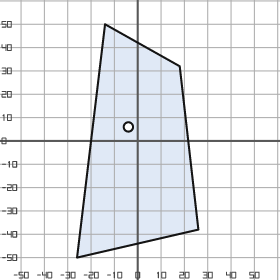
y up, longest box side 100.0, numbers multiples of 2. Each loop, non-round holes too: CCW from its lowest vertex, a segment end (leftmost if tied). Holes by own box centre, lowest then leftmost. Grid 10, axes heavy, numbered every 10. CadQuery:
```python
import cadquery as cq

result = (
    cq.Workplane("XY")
    .moveTo(-26.0, -50.0)
    .lineTo(26.0, -38.0)
    .lineTo(18.0, 32.0)
    .lineTo(-14.0, 50.0)
    .close()
    .moveTo(-4.0, 6.0)
    .circle(2.0)
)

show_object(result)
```